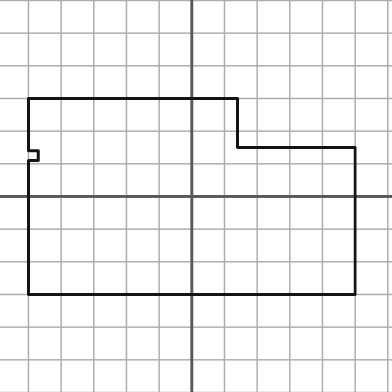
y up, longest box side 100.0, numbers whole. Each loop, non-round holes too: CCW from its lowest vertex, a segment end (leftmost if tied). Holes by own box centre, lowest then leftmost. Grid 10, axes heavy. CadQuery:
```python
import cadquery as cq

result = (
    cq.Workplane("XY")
    .moveTo(-50.0, -30.0)
    .lineTo(50.0, -30.0)
    .lineTo(50.0, 15.0)
    .lineTo(14.0, 15.0)
    .lineTo(14.0, 30.0)
    .lineTo(-50.0, 30.0)
    .lineTo(-50.0, 14.0)
    .lineTo(-47.0, 14.0)
    .lineTo(-47.0, 11.0)
    .lineTo(-50.0, 11.0)
    .close()
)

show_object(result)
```